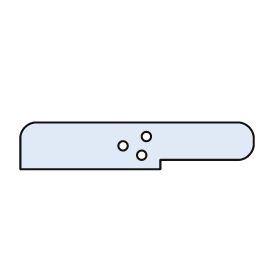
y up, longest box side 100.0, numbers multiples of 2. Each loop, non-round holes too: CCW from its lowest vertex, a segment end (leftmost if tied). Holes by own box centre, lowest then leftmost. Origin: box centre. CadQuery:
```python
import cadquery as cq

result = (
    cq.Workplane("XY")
    .moveTo(-50.0, -10.0)
    .lineTo(10.0, -10.0)
    .lineTo(10.0, -6.0)
    .lineTo(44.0, -6.0)
    .threePointArc((48.0, -4.0), (50.0, 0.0))
    .lineTo(50.0, 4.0)
    .threePointArc((48.0, 8.0), (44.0, 10.0))
    .lineTo(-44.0, 10.0)
    .threePointArc((-48.0, 8.0), (-50.0, 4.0))
    .close()
    .moveTo(2.0, -4.0)
    .circle(2.0)
    .moveTo(-6.0, 0.0)
    .circle(2.0)
    .moveTo(4.0, 4.0)
    .circle(2.0)
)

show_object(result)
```